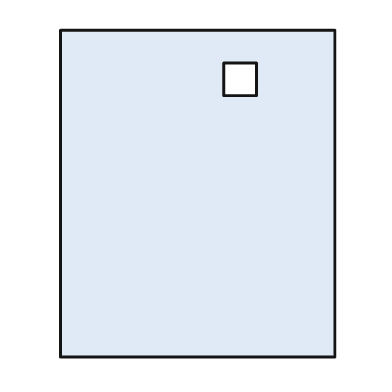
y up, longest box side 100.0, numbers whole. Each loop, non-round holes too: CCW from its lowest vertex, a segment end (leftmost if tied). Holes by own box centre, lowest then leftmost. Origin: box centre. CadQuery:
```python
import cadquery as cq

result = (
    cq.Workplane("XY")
    .moveTo(-42.0, -50.0)
    .lineTo(42.0, -50.0)
    .lineTo(42.0, 50.0)
    .lineTo(-42.0, 50.0)
    .close()
    .moveTo(8.0, 30.0)
    .lineTo(18.0, 30.0)
    .lineTo(18.0, 40.0)
    .lineTo(8.0, 40.0)
    .close()
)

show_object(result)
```